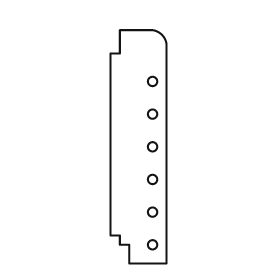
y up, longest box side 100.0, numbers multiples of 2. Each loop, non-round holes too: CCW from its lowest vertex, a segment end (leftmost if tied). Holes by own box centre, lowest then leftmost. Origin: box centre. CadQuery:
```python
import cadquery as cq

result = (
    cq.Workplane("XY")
    .moveTo(-4.0, -50.0)
    .lineTo(12.0, -50.0)
    .lineTo(12.0, 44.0)
    .threePointArc((10.0, 48.0), (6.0, 50.0))
    .lineTo(-8.0, 50.0)
    .lineTo(-8.0, 40.0)
    .lineTo(-12.0, 40.0)
    .lineTo(-12.0, -38.0)
    .lineTo(-8.0, -38.0)
    .lineTo(-8.0, -42.0)
    .lineTo(-4.0, -42.0)
    .close()
    .moveTo(6.0, -42.0)
    .circle(2.0)
    .moveTo(6.0, -28.0)
    .circle(2.0)
    .moveTo(6.0, -14.0)
    .circle(2.0)
    .moveTo(6.0, 0.0)
    .circle(2.0)
    .moveTo(6.0, 14.0)
    .circle(2.0)
    .moveTo(6.0, 28.0)
    .circle(2.0)
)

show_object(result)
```